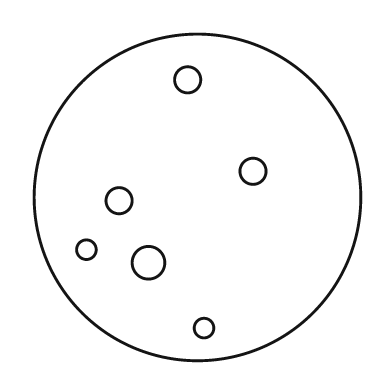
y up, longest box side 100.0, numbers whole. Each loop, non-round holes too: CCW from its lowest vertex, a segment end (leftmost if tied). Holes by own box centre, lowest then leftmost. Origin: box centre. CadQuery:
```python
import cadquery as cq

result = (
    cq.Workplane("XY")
    .moveTo(0.0, 0.0)
    .circle(50.0)
    .moveTo(2.0, -40.0)
    .circle(3.0)
    .moveTo(-15.0, -20.0)
    .circle(5.0)
    .moveTo(-34.0, -16.0)
    .circle(3.0)
    .moveTo(-24.0, -1.0)
    .circle(4.0)
    .moveTo(17.0, 8.0)
    .circle(4.0)
    .moveTo(-3.0, 36.0)
    .circle(4.0)
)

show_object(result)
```